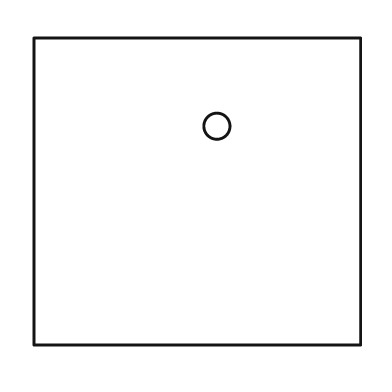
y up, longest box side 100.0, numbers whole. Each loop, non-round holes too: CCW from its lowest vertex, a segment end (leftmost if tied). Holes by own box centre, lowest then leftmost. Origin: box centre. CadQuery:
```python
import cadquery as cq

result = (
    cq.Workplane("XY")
    .moveTo(-50.0, -47.0)
    .lineTo(50.0, -47.0)
    .lineTo(50.0, 47.0)
    .lineTo(-50.0, 47.0)
    .close()
    .moveTo(6.0, 20.0)
    .circle(4.0)
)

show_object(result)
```